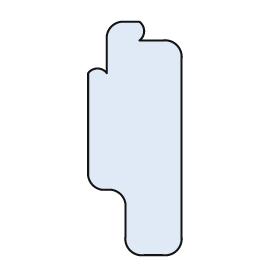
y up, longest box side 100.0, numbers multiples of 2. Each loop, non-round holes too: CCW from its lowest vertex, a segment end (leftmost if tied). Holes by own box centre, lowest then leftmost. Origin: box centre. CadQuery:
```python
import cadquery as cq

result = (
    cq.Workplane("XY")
    .moveTo(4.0, -50.0)
    .lineTo(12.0, -50.0)
    .threePointArc((18.0, -48.0), (20.0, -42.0))
    .lineTo(20.0, 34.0)
    .threePointArc((18.0, 40.0), (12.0, 42.0))
    .lineTo(2.0, 42.0)
    .threePointArc((4.0, 46.0), (2.0, 50.0))
    .lineTo(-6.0, 50.0)
    .threePointArc((-10.0, 48.0), (-12.0, 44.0))
    .lineTo(-12.0, 28.0)
    .threePointArc((-16.0, 30.0), (-20.0, 28.0))
    .lineTo(-20.0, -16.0)
    .threePointArc((-18.0, -20.0), (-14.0, -22.0))
    .lineTo(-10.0, -22.0)
    .threePointArc((-6.0, -24.0), (-4.0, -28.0))
    .lineTo(-4.0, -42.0)
    .threePointArc((-2.0, -48.0), (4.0, -50.0))
    .close()
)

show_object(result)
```